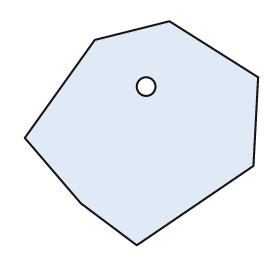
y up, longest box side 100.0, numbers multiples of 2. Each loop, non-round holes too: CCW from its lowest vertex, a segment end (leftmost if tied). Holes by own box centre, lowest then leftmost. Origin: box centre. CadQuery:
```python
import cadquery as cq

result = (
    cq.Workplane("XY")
    .moveTo(-2.0, -48.0)
    .lineTo(48.0, -14.0)
    .lineTo(50.0, 24.0)
    .lineTo(12.0, 48.0)
    .lineTo(-20.0, 40.0)
    .lineTo(-50.0, -2.0)
    .lineTo(-26.0, -30.0)
    .close()
    .moveTo(2.0, 20.0)
    .circle(4.0)
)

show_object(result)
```